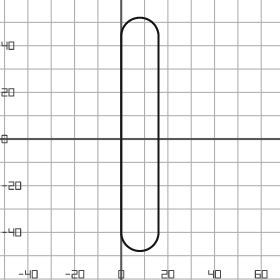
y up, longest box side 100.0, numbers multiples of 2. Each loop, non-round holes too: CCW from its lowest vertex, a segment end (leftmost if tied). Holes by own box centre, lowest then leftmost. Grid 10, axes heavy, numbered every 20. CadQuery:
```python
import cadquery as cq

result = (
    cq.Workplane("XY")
    .moveTo(0.0, -40.0)
    .threePointArc((8.0, -48.0), (16.0, -40.0))
    .lineTo(16.0, 44.0)
    .threePointArc((8.0, 52.0), (0.0, 44.0))
    .close()
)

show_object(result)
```